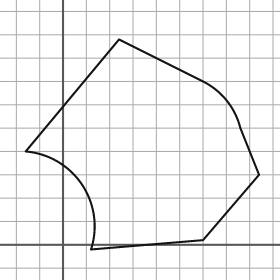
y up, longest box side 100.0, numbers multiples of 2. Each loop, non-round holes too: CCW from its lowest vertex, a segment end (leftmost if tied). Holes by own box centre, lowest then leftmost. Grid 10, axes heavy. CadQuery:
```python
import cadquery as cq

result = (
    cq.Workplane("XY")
    .moveTo(12.0, -2.0)
    .lineTo(60.0, 2.0)
    .lineTo(84.0, 30.0)
    .lineTo(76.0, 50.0)
    .threePointArc((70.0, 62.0), (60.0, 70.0))
    .lineTo(24.0, 88.0)
    .lineTo(-16.0, 40.0)
    .threePointArc((8.0, 26.0), (12.0, -2.0))
    .close()
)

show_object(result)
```